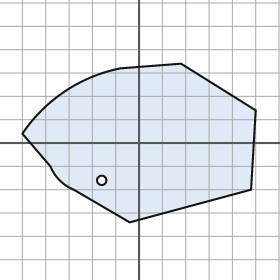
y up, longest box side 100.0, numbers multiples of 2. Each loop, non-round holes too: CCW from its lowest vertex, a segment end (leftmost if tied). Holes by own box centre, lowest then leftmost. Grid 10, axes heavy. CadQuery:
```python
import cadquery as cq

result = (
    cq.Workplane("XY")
    .moveTo(-4.0, -34.0)
    .lineTo(48.0, -20.0)
    .lineTo(50.0, 14.0)
    .lineTo(18.0, 34.0)
    .lineTo(-8.0, 32.0)
    .threePointArc((-32.0, 22.0), (-50.0, 4.0))
    .lineTo(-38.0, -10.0)
    .threePointArc((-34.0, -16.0), (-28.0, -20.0))
    .close()
    .moveTo(-16.0, -16.0)
    .circle(2.0)
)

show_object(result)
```